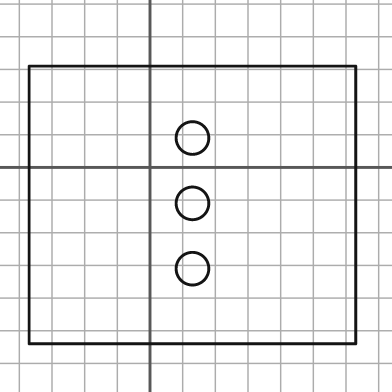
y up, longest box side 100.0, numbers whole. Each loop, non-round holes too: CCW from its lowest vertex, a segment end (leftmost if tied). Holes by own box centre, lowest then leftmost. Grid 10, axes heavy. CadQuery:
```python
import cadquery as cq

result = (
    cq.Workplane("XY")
    .moveTo(-37.0, -54.0)
    .lineTo(63.0, -54.0)
    .lineTo(63.0, 31.0)
    .lineTo(-37.0, 31.0)
    .close()
    .moveTo(13.0, -31.0)
    .circle(5.0)
    .moveTo(13.0, -11.0)
    .circle(5.0)
    .moveTo(13.0, 9.0)
    .circle(5.0)
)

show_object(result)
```